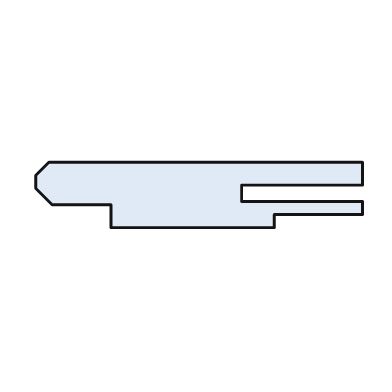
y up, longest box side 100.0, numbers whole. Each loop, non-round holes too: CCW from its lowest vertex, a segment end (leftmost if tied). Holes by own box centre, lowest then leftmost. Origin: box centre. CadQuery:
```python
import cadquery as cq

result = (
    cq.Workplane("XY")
    .moveTo(-27.0, -10.0)
    .lineTo(23.0, -10.0)
    .lineTo(23.0, -6.0)
    .lineTo(50.0, -6.0)
    .lineTo(50.0, -2.0)
    .lineTo(13.0, -2.0)
    .lineTo(13.0, 3.0)
    .lineTo(50.0, 3.0)
    .lineTo(50.0, 10.0)
    .lineTo(-46.0, 10.0)
    .lineTo(-50.0, 6.0)
    .lineTo(-50.0, 2.0)
    .lineTo(-45.0, -3.0)
    .lineTo(-27.0, -3.0)
    .close()
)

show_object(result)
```